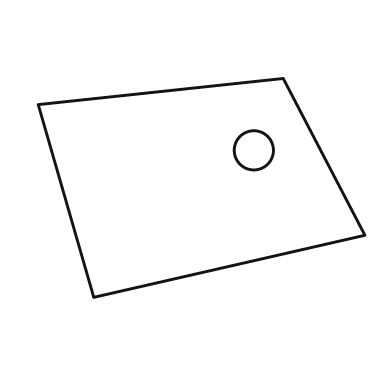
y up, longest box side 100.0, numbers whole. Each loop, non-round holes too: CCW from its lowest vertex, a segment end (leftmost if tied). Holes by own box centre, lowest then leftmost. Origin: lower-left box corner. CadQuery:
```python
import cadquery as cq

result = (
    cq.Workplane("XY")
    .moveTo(17.0, 0.0)
    .lineTo(100.0, 19.0)
    .lineTo(75.0, 67.0)
    .lineTo(0.0, 59.0)
    .close()
    .moveTo(66.0, 45.0)
    .circle(6.0)
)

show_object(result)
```